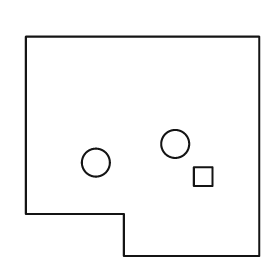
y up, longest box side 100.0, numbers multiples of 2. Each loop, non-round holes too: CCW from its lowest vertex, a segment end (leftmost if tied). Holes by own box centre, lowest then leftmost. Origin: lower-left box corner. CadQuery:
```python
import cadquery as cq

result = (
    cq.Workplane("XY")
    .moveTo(42.0, 0.0)
    .lineTo(100.0, 0.0)
    .lineTo(100.0, 94.0)
    .lineTo(0.0, 94.0)
    .lineTo(0.0, 18.0)
    .lineTo(42.0, 18.0)
    .close()
    .moveTo(72.0, 30.0)
    .lineTo(80.0, 30.0)
    .lineTo(80.0, 38.0)
    .lineTo(72.0, 38.0)
    .close()
    .moveTo(30.0, 40.0)
    .circle(6.0)
    .moveTo(64.0, 48.0)
    .circle(6.0)
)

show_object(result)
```